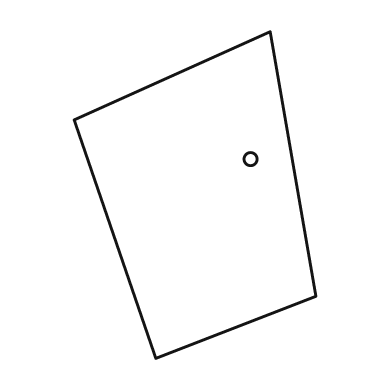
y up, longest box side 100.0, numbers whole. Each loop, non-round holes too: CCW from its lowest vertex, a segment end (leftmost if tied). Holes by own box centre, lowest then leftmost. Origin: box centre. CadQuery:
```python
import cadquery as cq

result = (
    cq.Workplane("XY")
    .moveTo(-12.0, -50.0)
    .lineTo(37.0, -31.0)
    .lineTo(23.0, 50.0)
    .lineTo(-37.0, 23.0)
    .close()
    .moveTo(17.0, 11.0)
    .circle(2.0)
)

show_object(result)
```